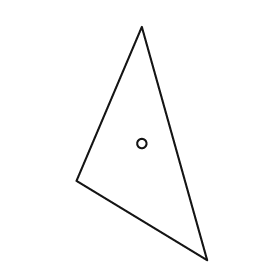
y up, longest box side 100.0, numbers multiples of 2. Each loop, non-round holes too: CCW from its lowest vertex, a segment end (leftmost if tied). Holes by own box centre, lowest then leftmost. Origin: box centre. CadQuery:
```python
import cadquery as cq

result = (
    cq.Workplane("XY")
    .moveTo(28.0, -50.0)
    .lineTo(0.0, 50.0)
    .lineTo(-28.0, -16.0)
    .close()
    .moveTo(0.0, 0.0)
    .circle(2.0)
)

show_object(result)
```